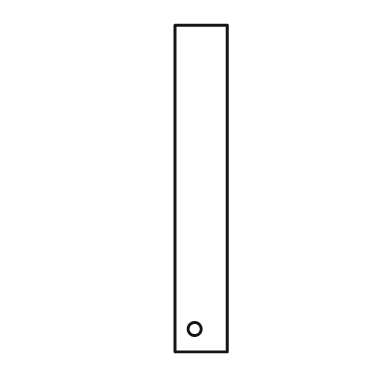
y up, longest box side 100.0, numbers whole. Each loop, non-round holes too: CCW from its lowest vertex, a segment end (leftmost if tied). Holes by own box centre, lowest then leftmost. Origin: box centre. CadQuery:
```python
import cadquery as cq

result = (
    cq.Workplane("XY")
    .moveTo(-8.0, -50.0)
    .lineTo(8.0, -50.0)
    .lineTo(8.0, 50.0)
    .lineTo(-8.0, 50.0)
    .close()
    .moveTo(-2.0, -43.0)
    .circle(2.0)
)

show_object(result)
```